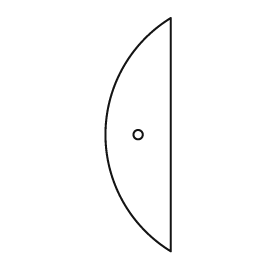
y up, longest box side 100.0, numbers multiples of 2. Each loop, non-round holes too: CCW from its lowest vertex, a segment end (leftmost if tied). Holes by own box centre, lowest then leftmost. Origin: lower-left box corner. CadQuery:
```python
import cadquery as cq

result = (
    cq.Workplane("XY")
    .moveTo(28.0, 0.0)
    .lineTo(28.0, 100.0)
    .threePointArc((0.0, 50.0), (28.0, 0.0))
    .close()
    .moveTo(14.0, 50.0)
    .circle(2.0)
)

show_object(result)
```